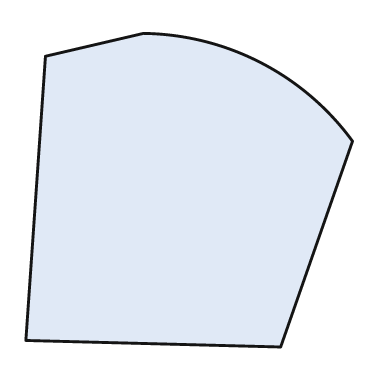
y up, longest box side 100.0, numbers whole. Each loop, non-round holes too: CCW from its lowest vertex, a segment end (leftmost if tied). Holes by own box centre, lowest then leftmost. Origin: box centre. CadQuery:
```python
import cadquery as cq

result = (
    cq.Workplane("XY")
    .moveTo(28.0, -48.0)
    .lineTo(50.0, 15.0)
    .threePointArc((22.0, 39.0), (-14.0, 48.0))
    .lineTo(-44.0, 41.0)
    .lineTo(-50.0, -46.0)
    .close()
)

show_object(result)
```